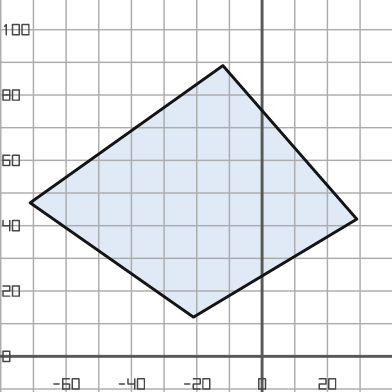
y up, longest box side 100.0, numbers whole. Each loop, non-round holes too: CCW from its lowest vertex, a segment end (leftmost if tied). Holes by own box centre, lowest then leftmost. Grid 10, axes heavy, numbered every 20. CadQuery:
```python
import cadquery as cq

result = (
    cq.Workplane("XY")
    .moveTo(-21.0, 12.0)
    .lineTo(29.0, 42.0)
    .lineTo(-12.0, 89.0)
    .lineTo(-71.0, 47.0)
    .close()
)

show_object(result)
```